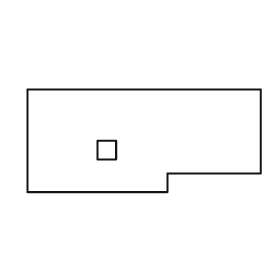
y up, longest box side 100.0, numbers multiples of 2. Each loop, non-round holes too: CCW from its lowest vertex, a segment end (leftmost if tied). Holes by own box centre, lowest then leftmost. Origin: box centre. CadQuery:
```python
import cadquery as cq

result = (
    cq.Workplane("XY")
    .moveTo(-50.0, -22.0)
    .lineTo(10.0, -22.0)
    .lineTo(10.0, -14.0)
    .lineTo(50.0, -14.0)
    .lineTo(50.0, 22.0)
    .lineTo(-50.0, 22.0)
    .close()
    .moveTo(-20.0, -8.0)
    .lineTo(-12.0, -8.0)
    .lineTo(-12.0, 0.0)
    .lineTo(-20.0, 0.0)
    .close()
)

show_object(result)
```